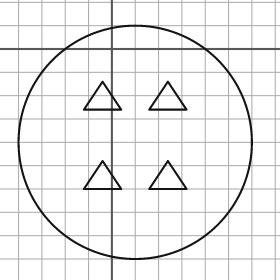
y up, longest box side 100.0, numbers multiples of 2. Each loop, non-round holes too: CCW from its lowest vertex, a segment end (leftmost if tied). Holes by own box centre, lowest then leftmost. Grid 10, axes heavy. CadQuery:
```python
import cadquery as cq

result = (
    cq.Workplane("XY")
    .moveTo(10.0, -40.0)
    .circle(50.0)
    .moveTo(-12.0, -60.0)
    .lineTo(4.0, -60.0)
    .lineTo(-4.0, -48.0)
    .close()
    .moveTo(16.0, -60.0)
    .lineTo(32.0, -60.0)
    .lineTo(24.0, -48.0)
    .close()
    .moveTo(-12.0, -26.0)
    .lineTo(4.0, -26.0)
    .lineTo(-4.0, -14.0)
    .close()
    .moveTo(16.0, -26.0)
    .lineTo(32.0, -26.0)
    .lineTo(24.0, -14.0)
    .close()
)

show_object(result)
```